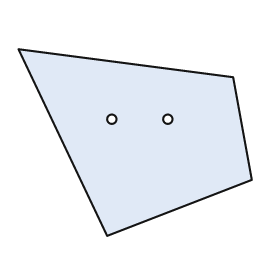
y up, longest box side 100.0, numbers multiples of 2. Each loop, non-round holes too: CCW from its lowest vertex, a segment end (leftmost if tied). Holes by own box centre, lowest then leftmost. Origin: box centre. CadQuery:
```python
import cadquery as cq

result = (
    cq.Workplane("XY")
    .moveTo(-12.0, -40.0)
    .lineTo(50.0, -16.0)
    .lineTo(42.0, 28.0)
    .lineTo(-50.0, 40.0)
    .close()
    .moveTo(-10.0, 10.0)
    .circle(2.0)
    .moveTo(14.0, 10.0)
    .circle(2.0)
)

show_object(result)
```